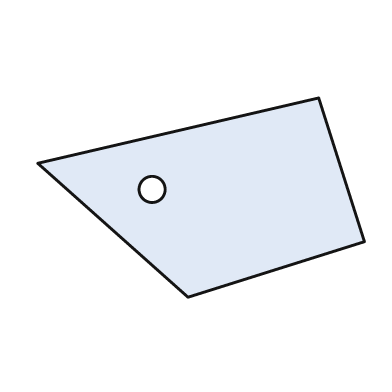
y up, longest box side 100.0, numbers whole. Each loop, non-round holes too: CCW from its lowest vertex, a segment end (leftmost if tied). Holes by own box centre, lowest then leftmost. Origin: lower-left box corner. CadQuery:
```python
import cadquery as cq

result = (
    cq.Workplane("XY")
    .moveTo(46.0, 0.0)
    .lineTo(100.0, 17.0)
    .lineTo(86.0, 61.0)
    .lineTo(0.0, 41.0)
    .close()
    .moveTo(35.0, 33.0)
    .circle(4.0)
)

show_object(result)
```